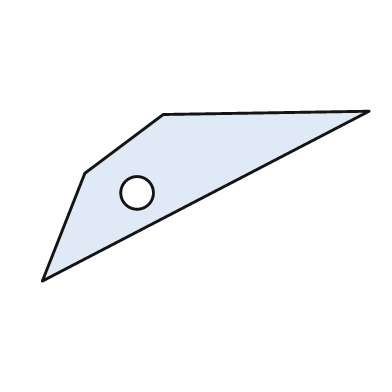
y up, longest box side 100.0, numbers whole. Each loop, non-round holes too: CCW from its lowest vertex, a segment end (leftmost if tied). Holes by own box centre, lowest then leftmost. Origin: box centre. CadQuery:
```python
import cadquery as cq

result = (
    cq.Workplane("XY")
    .moveTo(-50.0, -26.0)
    .lineTo(50.0, 26.0)
    .lineTo(-13.0, 25.0)
    .lineTo(-37.0, 7.0)
    .close()
    .moveTo(-21.0, 1.0)
    .circle(5.0)
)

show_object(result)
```